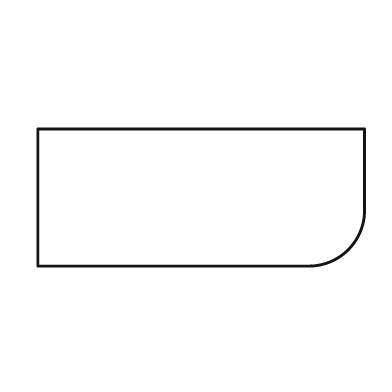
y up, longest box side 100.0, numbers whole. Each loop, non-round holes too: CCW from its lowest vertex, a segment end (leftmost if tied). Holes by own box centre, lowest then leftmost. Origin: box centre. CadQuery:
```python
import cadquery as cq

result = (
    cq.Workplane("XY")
    .moveTo(-50.0, -21.0)
    .lineTo(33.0, -21.0)
    .threePointArc((45.0, -16.0), (50.0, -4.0))
    .lineTo(50.0, 21.0)
    .lineTo(-50.0, 21.0)
    .close()
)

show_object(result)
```